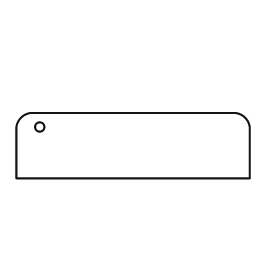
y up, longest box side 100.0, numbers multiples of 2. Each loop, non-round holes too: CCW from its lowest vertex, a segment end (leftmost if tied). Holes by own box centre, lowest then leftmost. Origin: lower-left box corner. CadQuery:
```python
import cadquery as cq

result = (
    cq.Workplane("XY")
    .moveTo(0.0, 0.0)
    .lineTo(100.0, 0.0)
    .lineTo(100.0, 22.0)
    .threePointArc((98.0, 26.0), (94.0, 28.0))
    .lineTo(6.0, 28.0)
    .threePointArc((2.0, 26.0), (0.0, 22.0))
    .close()
    .moveTo(10.0, 22.0)
    .circle(2.0)
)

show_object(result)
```